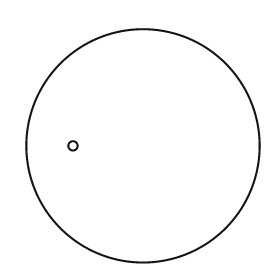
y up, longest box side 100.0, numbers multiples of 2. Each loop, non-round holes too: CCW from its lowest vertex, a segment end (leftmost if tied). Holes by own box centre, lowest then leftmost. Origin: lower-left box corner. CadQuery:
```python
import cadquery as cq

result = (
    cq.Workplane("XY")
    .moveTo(50.0, 50.0)
    .circle(50.0)
    .moveTo(20.0, 50.0)
    .circle(2.0)
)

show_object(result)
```